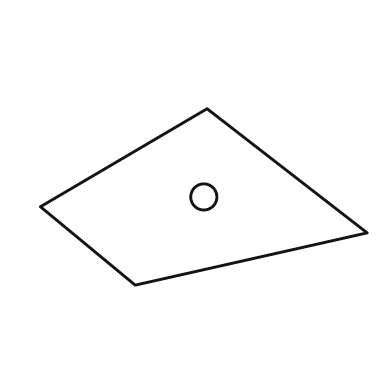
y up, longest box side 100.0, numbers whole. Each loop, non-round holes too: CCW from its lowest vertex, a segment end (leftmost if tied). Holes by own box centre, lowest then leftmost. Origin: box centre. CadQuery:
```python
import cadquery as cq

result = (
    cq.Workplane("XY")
    .moveTo(-21.0, -27.0)
    .lineTo(50.0, -11.0)
    .lineTo(1.0, 27.0)
    .lineTo(-50.0, -3.0)
    .close()
    .moveTo(0.0, 0.0)
    .circle(4.0)
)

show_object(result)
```